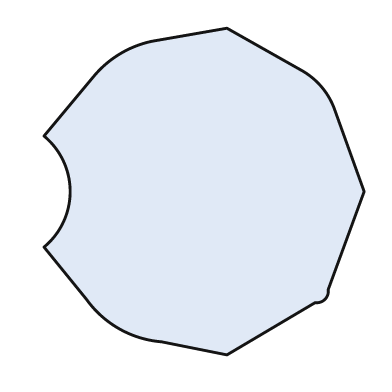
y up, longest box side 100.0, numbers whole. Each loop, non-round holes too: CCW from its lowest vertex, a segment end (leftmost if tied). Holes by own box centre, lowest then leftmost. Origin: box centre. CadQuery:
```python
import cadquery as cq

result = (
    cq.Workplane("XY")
    .moveTo(7.0, -50.0)
    .lineTo(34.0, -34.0)
    .threePointArc((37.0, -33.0), (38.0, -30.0))
    .lineTo(49.0, 0.0)
    .lineTo(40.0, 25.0)
    .threePointArc((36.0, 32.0), (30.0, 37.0))
    .lineTo(7.0, 50.0)
    .lineTo(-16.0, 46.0)
    .threePointArc((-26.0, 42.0), (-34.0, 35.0))
    .lineTo(-49.0, 17.0)
    .threePointArc((-41.0, 0.0), (-49.0, -17.0))
    .lineTo(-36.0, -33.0)
    .threePointArc((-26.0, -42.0), (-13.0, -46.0))
    .close()
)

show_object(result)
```